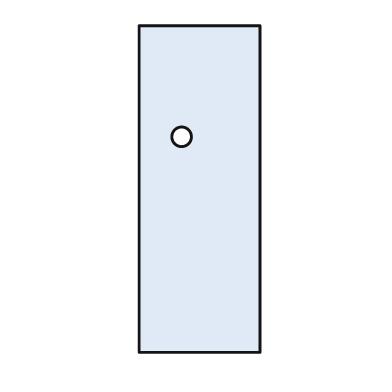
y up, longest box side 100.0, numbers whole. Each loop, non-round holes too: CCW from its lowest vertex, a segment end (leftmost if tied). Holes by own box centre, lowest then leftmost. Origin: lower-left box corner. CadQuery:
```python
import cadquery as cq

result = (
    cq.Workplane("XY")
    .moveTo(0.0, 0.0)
    .lineTo(37.0, 0.0)
    .lineTo(37.0, 100.0)
    .lineTo(0.0, 100.0)
    .close()
    .moveTo(13.0, 66.0)
    .circle(3.0)
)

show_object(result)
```